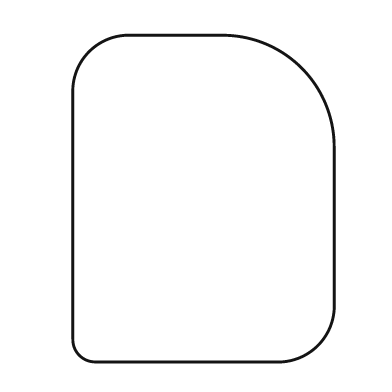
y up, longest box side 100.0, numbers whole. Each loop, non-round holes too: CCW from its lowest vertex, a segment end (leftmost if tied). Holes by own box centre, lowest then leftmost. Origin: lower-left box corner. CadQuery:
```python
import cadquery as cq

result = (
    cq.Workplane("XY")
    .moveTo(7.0, 0.0)
    .lineTo(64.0, 0.0)
    .threePointArc((75.0, 5.0), (80.0, 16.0))
    .lineTo(80.0, 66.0)
    .threePointArc((70.0, 90.0), (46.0, 100.0))
    .lineTo(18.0, 100.0)
    .threePointArc((5.0, 95.0), (0.0, 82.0))
    .lineTo(0.0, 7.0)
    .threePointArc((2.0, 2.0), (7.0, 0.0))
    .close()
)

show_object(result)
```